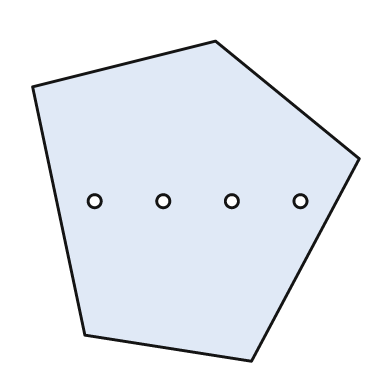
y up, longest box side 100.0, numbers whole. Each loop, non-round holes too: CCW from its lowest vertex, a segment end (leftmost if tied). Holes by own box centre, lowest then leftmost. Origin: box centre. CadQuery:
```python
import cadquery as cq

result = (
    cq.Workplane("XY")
    .moveTo(17.0, -49.0)
    .lineTo(50.0, 13.0)
    .lineTo(6.0, 49.0)
    .lineTo(-50.0, 35.0)
    .lineTo(-34.0, -41.0)
    .close()
    .moveTo(-31.0, 0.0)
    .circle(2.0)
    .moveTo(-10.0, 0.0)
    .circle(2.0)
    .moveTo(11.0, 0.0)
    .circle(2.0)
    .moveTo(32.0, 0.0)
    .circle(2.0)
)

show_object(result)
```